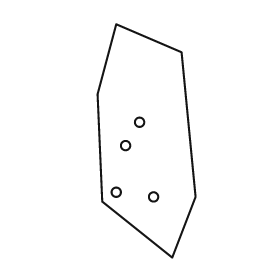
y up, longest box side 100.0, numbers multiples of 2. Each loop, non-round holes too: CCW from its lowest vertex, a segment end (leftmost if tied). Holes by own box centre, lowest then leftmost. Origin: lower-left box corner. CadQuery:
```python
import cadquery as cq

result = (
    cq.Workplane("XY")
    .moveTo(32.0, 0.0)
    .lineTo(42.0, 26.0)
    .lineTo(36.0, 88.0)
    .lineTo(8.0, 100.0)
    .lineTo(0.0, 70.0)
    .lineTo(2.0, 24.0)
    .close()
    .moveTo(24.0, 26.0)
    .circle(2.0)
    .moveTo(8.0, 28.0)
    .circle(2.0)
    .moveTo(12.0, 48.0)
    .circle(2.0)
    .moveTo(18.0, 58.0)
    .circle(2.0)
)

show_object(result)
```